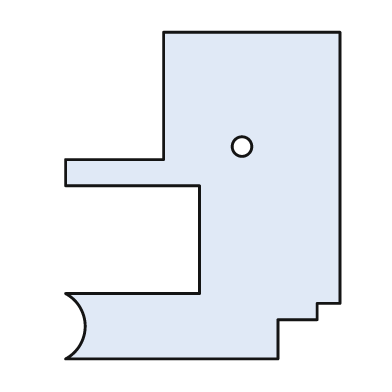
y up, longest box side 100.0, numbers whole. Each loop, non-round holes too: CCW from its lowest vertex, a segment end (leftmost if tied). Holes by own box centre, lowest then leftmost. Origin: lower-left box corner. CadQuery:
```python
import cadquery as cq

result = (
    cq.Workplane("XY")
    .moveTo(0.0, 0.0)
    .lineTo(65.0, 0.0)
    .lineTo(65.0, 12.0)
    .lineTo(77.0, 12.0)
    .lineTo(77.0, 17.0)
    .lineTo(84.0, 17.0)
    .lineTo(84.0, 100.0)
    .lineTo(30.0, 100.0)
    .lineTo(30.0, 61.0)
    .lineTo(0.0, 61.0)
    .lineTo(0.0, 53.0)
    .lineTo(41.0, 53.0)
    .lineTo(41.0, 20.0)
    .lineTo(0.0, 20.0)
    .threePointArc((6.0, 10.0), (0.0, 0.0))
    .close()
    .moveTo(54.0, 65.0)
    .circle(3.0)
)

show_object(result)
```